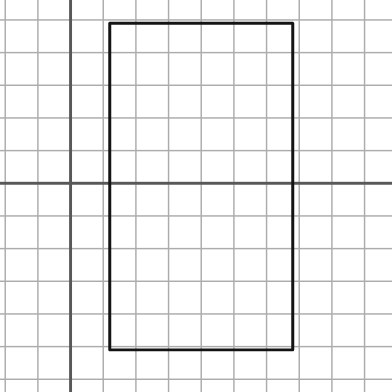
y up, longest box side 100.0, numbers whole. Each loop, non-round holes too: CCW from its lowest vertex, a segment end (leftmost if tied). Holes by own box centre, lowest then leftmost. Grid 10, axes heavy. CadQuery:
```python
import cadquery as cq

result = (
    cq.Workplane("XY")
    .moveTo(12.0, -51.0)
    .lineTo(68.0, -51.0)
    .lineTo(68.0, 49.0)
    .lineTo(12.0, 49.0)
    .close()
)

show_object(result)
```